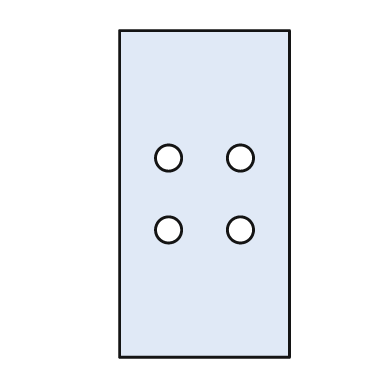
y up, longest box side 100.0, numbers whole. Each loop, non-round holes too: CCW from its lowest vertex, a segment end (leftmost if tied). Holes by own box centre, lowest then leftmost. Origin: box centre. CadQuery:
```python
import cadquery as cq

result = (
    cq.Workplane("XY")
    .moveTo(-26.0, -50.0)
    .lineTo(26.0, -50.0)
    .lineTo(26.0, 50.0)
    .lineTo(-26.0, 50.0)
    .close()
    .moveTo(-11.0, -11.0)
    .circle(4.0)
    .moveTo(11.0, -11.0)
    .circle(4.0)
    .moveTo(-11.0, 11.0)
    .circle(4.0)
    .moveTo(11.0, 11.0)
    .circle(4.0)
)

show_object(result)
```